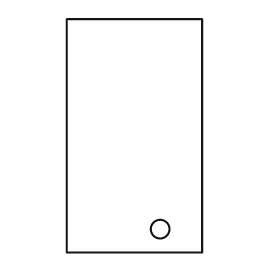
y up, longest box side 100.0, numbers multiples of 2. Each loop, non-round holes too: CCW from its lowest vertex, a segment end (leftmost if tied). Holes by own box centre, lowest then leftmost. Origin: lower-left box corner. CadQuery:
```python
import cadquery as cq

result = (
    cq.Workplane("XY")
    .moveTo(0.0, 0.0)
    .lineTo(58.0, 0.0)
    .lineTo(58.0, 100.0)
    .lineTo(0.0, 100.0)
    .close()
    .moveTo(40.0, 10.0)
    .circle(4.0)
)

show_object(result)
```